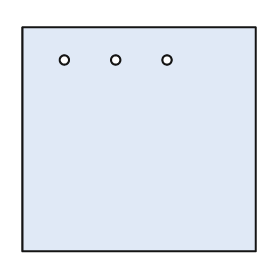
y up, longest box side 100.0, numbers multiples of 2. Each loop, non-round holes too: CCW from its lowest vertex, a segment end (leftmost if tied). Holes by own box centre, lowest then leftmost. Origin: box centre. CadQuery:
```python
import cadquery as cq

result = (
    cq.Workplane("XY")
    .moveTo(-50.0, -48.0)
    .lineTo(50.0, -48.0)
    .lineTo(50.0, 48.0)
    .lineTo(-50.0, 48.0)
    .close()
    .moveTo(-32.0, 34.0)
    .circle(2.0)
    .moveTo(-10.0, 34.0)
    .circle(2.0)
    .moveTo(12.0, 34.0)
    .circle(2.0)
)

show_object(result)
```